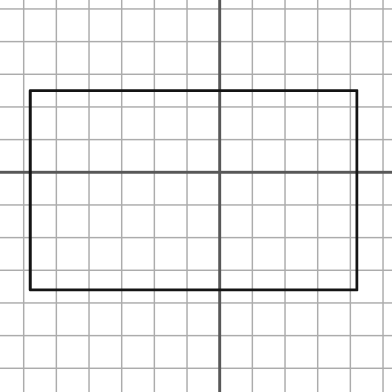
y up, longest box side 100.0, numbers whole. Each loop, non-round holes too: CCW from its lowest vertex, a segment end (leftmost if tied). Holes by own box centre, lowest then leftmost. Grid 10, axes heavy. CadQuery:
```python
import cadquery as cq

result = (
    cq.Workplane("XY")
    .moveTo(-58.0, -36.0)
    .lineTo(42.0, -36.0)
    .lineTo(42.0, 25.0)
    .lineTo(-58.0, 25.0)
    .close()
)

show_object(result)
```